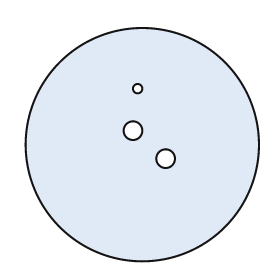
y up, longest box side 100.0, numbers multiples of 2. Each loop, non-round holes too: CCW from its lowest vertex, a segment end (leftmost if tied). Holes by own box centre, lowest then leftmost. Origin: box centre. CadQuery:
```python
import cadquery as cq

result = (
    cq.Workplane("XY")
    .moveTo(0.0, 0.0)
    .circle(50.0)
    .moveTo(10.0, -6.0)
    .circle(4.0)
    .moveTo(-4.0, 6.0)
    .circle(4.0)
    .moveTo(-2.0, 24.0)
    .circle(2.0)
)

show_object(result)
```